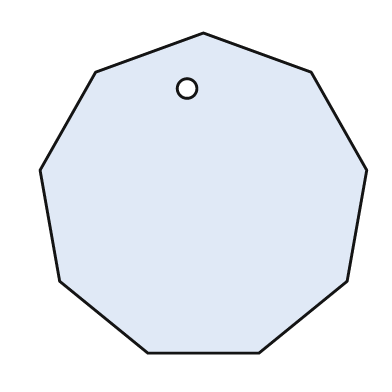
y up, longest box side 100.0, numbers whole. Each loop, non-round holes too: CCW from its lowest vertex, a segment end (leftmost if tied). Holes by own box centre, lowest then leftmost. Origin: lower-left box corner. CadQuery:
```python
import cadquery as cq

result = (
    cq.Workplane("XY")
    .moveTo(33.0, 0.0)
    .lineTo(67.0, 0.0)
    .lineTo(94.0, 22.0)
    .lineTo(100.0, 56.0)
    .lineTo(83.0, 86.0)
    .lineTo(50.0, 98.0)
    .lineTo(17.0, 86.0)
    .lineTo(0.0, 56.0)
    .lineTo(6.0, 22.0)
    .close()
    .moveTo(45.0, 81.0)
    .circle(3.0)
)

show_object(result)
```